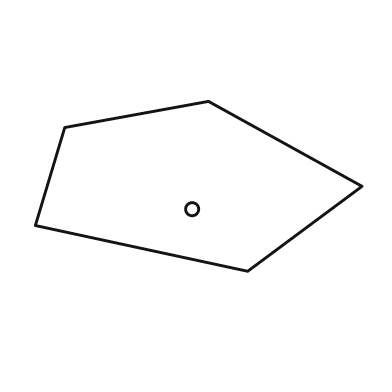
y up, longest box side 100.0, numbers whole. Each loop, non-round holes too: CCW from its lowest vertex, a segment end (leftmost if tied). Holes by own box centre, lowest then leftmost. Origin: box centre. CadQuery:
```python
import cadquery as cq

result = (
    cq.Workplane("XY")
    .moveTo(15.0, -26.0)
    .lineTo(50.0, 0.0)
    .lineTo(3.0, 26.0)
    .lineTo(-41.0, 18.0)
    .lineTo(-50.0, -12.0)
    .close()
    .moveTo(-2.0, -7.0)
    .circle(2.0)
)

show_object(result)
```